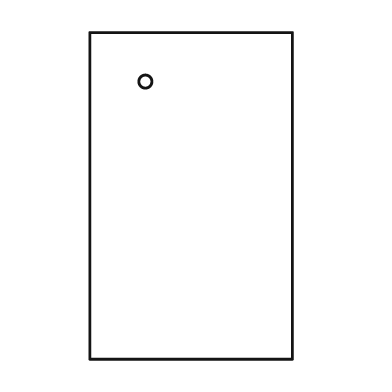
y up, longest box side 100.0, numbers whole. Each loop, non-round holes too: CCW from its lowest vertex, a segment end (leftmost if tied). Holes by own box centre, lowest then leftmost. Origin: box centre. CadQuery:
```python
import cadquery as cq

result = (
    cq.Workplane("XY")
    .moveTo(-31.0, -50.0)
    .lineTo(31.0, -50.0)
    .lineTo(31.0, 50.0)
    .lineTo(-31.0, 50.0)
    .close()
    .moveTo(-14.0, 35.0)
    .circle(2.0)
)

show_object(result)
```